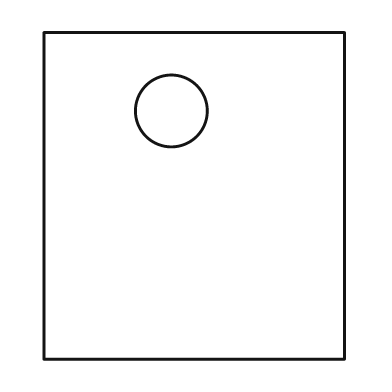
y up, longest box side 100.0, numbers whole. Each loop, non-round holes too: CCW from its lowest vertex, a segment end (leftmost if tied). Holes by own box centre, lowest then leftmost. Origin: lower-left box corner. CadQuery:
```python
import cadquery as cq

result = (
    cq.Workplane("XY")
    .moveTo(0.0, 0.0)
    .lineTo(92.0, 0.0)
    .lineTo(92.0, 100.0)
    .lineTo(0.0, 100.0)
    .close()
    .moveTo(39.0, 76.0)
    .circle(11.0)
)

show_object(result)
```